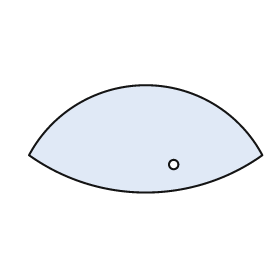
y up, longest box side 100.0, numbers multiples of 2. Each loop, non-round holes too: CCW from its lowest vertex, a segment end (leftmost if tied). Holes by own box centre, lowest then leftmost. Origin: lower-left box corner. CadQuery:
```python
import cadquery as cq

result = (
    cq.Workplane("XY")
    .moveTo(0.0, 16.0)
    .threePointArc((50.0, 0.0), (100.0, 16.0))
    .threePointArc((50.0, 46.0), (0.0, 16.0))
    .close()
    .moveTo(62.0, 12.0)
    .circle(2.0)
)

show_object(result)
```